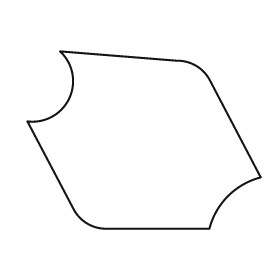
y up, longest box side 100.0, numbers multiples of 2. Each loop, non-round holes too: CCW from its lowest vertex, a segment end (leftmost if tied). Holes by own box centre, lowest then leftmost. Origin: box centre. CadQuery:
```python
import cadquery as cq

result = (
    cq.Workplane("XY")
    .moveTo(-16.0, -38.0)
    .lineTo(28.0, -38.0)
    .threePointArc((36.0, -24.0), (50.0, -16.0))
    .lineTo(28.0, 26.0)
    .threePointArc((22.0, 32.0), (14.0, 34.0))
    .lineTo(-36.0, 38.0)
    .threePointArc((-32.0, 18.0), (-50.0, 8.0))
    .lineTo(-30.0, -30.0)
    .threePointArc((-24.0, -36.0), (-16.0, -38.0))
    .close()
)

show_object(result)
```